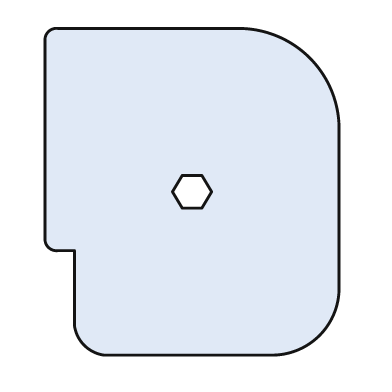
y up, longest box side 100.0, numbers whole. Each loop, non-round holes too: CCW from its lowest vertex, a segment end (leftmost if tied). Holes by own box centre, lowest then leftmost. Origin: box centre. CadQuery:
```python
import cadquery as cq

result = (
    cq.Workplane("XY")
    .moveTo(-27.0, -50.0)
    .lineTo(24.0, -50.0)
    .threePointArc((39.0, -44.0), (45.0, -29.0))
    .lineTo(45.0, 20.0)
    .threePointArc((36.0, 41.0), (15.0, 50.0))
    .lineTo(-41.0, 50.0)
    .threePointArc((-44.0, 49.0), (-45.0, 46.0))
    .lineTo(-45.0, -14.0)
    .threePointArc((-44.0, -17.0), (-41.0, -18.0))
    .lineTo(-36.0, -18.0)
    .lineTo(-36.0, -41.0)
    .threePointArc((-33.0, -47.0), (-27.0, -50.0))
    .close()
    .moveTo(-3.0, -5.0)
    .lineTo(3.0, -5.0)
    .lineTo(6.0, 0.0)
    .lineTo(3.0, 5.0)
    .lineTo(-3.0, 5.0)
    .lineTo(-6.0, 0.0)
    .close()
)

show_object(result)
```